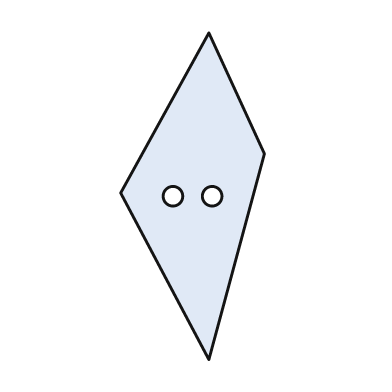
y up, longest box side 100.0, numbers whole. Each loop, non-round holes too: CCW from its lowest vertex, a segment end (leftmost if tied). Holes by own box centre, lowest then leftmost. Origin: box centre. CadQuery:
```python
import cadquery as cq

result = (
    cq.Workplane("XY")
    .moveTo(5.0, -50.0)
    .lineTo(22.0, 13.0)
    .lineTo(5.0, 50.0)
    .lineTo(-22.0, 1.0)
    .close()
    .moveTo(-6.0, 0.0)
    .circle(3.0)
    .moveTo(6.0, 0.0)
    .circle(3.0)
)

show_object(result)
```